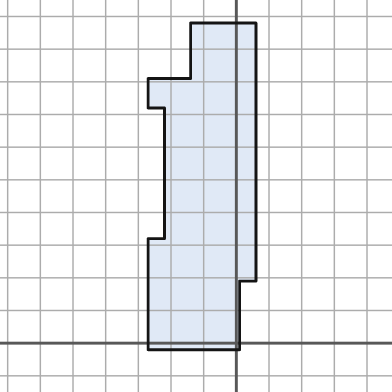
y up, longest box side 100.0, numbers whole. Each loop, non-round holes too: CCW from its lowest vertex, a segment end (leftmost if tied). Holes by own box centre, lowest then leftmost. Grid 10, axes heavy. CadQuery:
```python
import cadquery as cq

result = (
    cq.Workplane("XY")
    .moveTo(-27.0, -2.0)
    .lineTo(1.0, -2.0)
    .lineTo(1.0, 19.0)
    .lineTo(6.0, 19.0)
    .lineTo(6.0, 98.0)
    .lineTo(-14.0, 98.0)
    .lineTo(-14.0, 81.0)
    .lineTo(-27.0, 81.0)
    .lineTo(-27.0, 72.0)
    .lineTo(-22.0, 72.0)
    .lineTo(-22.0, 32.0)
    .lineTo(-27.0, 32.0)
    .close()
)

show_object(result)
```